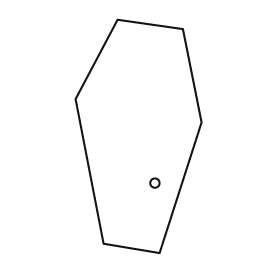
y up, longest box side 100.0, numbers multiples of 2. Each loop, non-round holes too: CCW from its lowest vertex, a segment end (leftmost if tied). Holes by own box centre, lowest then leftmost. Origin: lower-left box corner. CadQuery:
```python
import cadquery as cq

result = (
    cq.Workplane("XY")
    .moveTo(36.0, 0.0)
    .lineTo(54.0, 56.0)
    .lineTo(46.0, 96.0)
    .lineTo(18.0, 100.0)
    .lineTo(0.0, 66.0)
    .lineTo(12.0, 4.0)
    .close()
    .moveTo(34.0, 30.0)
    .circle(2.0)
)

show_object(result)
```